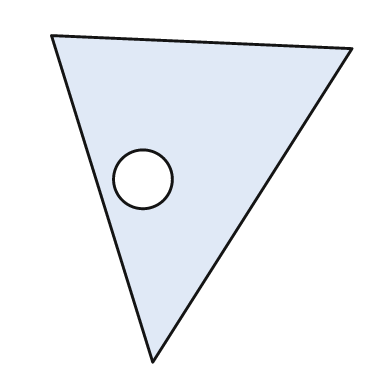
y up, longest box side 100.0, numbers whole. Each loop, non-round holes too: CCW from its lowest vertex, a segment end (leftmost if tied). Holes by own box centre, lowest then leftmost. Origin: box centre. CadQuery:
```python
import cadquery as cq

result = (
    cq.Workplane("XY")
    .moveTo(-15.0, -50.0)
    .lineTo(46.0, 46.0)
    .lineTo(-46.0, 50.0)
    .close()
    .moveTo(-18.0, 6.0)
    .circle(9.0)
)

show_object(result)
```